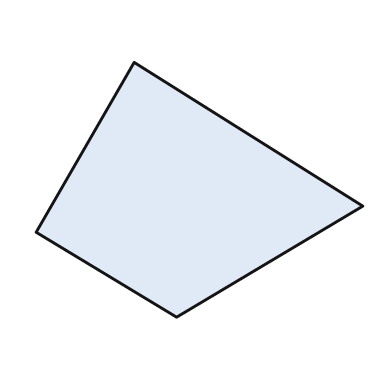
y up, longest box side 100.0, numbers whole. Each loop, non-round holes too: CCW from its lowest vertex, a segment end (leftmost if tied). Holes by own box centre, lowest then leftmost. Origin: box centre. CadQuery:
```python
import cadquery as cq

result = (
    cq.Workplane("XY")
    .moveTo(-7.0, -39.0)
    .lineTo(50.0, -5.0)
    .lineTo(-20.0, 39.0)
    .lineTo(-50.0, -13.0)
    .close()
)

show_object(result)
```